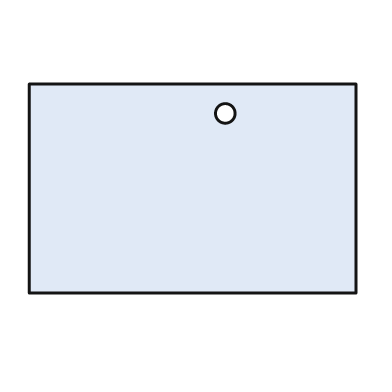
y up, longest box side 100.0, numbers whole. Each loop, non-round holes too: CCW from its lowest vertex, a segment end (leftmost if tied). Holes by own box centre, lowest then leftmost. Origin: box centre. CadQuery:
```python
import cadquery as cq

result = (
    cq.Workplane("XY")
    .moveTo(-50.0, -32.0)
    .lineTo(50.0, -32.0)
    .lineTo(50.0, 32.0)
    .lineTo(-50.0, 32.0)
    .close()
    .moveTo(10.0, 23.0)
    .circle(3.0)
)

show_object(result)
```